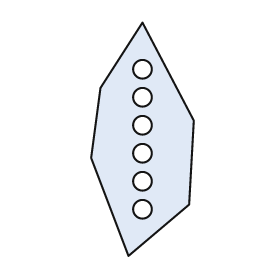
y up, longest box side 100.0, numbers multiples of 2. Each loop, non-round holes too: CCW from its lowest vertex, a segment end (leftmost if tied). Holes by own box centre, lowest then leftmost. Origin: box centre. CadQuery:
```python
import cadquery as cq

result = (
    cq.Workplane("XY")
    .moveTo(-6.0, -50.0)
    .lineTo(20.0, -28.0)
    .lineTo(22.0, 8.0)
    .lineTo(0.0, 50.0)
    .lineTo(-18.0, 22.0)
    .lineTo(-22.0, -8.0)
    .close()
    .moveTo(0.0, -30.0)
    .circle(4.0)
    .moveTo(0.0, -18.0)
    .circle(4.0)
    .moveTo(0.0, -6.0)
    .circle(4.0)
    .moveTo(0.0, 6.0)
    .circle(4.0)
    .moveTo(0.0, 18.0)
    .circle(4.0)
    .moveTo(0.0, 30.0)
    .circle(4.0)
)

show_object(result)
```